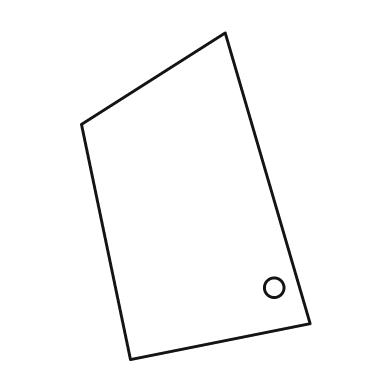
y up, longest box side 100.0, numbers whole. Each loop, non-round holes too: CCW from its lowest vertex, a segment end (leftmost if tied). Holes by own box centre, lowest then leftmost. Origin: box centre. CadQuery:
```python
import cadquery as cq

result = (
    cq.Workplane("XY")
    .moveTo(-20.0, -50.0)
    .lineTo(35.0, -39.0)
    .lineTo(9.0, 50.0)
    .lineTo(-35.0, 22.0)
    .close()
    .moveTo(24.0, -28.0)
    .circle(3.0)
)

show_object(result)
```